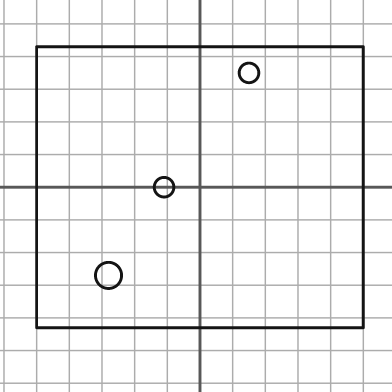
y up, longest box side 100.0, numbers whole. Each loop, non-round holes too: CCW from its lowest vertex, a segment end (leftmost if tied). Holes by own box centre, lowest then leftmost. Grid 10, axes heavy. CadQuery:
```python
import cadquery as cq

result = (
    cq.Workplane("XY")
    .moveTo(-50.0, -43.0)
    .lineTo(50.0, -43.0)
    .lineTo(50.0, 43.0)
    .lineTo(-50.0, 43.0)
    .close()
    .moveTo(-28.0, -27.0)
    .circle(4.0)
    .moveTo(-11.0, 0.0)
    .circle(3.0)
    .moveTo(15.0, 35.0)
    .circle(3.0)
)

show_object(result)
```